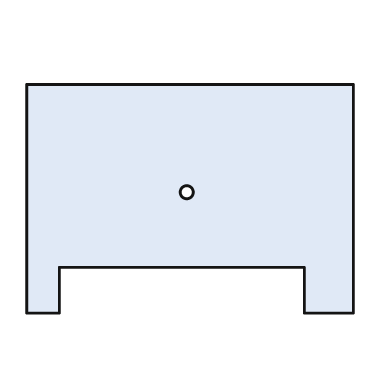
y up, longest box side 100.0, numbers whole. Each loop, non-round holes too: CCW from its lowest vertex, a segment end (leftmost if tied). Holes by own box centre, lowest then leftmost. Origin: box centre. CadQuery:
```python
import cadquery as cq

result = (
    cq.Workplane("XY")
    .moveTo(-50.0, -35.0)
    .lineTo(-40.0, -35.0)
    .lineTo(-40.0, -21.0)
    .lineTo(35.0, -21.0)
    .lineTo(35.0, -35.0)
    .lineTo(50.0, -35.0)
    .lineTo(50.0, 35.0)
    .lineTo(-50.0, 35.0)
    .close()
    .moveTo(-1.0, 2.0)
    .circle(2.0)
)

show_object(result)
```